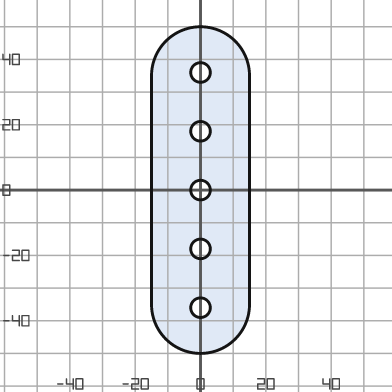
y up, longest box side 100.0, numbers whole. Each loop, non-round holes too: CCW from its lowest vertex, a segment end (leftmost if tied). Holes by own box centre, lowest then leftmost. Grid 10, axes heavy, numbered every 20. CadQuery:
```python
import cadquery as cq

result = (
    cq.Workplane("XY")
    .moveTo(-15.0, -35.0)
    .threePointArc((0.0, -50.0), (15.0, -35.0))
    .lineTo(15.0, 35.0)
    .threePointArc((0.0, 50.0), (-15.0, 35.0))
    .close()
    .moveTo(0.0, -36.0)
    .circle(3.0)
    .moveTo(0.0, -18.0)
    .circle(3.0)
    .moveTo(0.0, 0.0)
    .circle(3.0)
    .moveTo(0.0, 18.0)
    .circle(3.0)
    .moveTo(0.0, 36.0)
    .circle(3.0)
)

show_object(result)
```